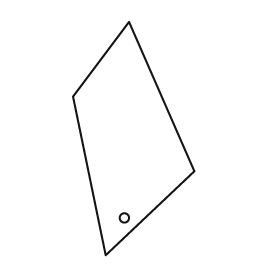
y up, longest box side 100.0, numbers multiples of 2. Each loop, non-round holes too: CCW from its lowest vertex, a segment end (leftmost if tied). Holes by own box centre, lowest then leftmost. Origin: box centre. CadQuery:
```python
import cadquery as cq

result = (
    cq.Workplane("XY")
    .moveTo(-12.0, -50.0)
    .lineTo(26.0, -14.0)
    .lineTo(-2.0, 50.0)
    .lineTo(-26.0, 18.0)
    .close()
    .moveTo(-4.0, -34.0)
    .circle(2.0)
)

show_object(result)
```